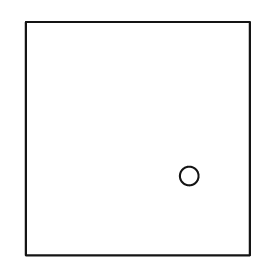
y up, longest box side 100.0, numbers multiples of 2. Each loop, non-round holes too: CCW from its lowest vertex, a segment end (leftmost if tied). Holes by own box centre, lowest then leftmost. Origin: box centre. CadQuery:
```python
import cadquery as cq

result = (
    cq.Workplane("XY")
    .moveTo(-48.0, -50.0)
    .lineTo(48.0, -50.0)
    .lineTo(48.0, 50.0)
    .lineTo(-48.0, 50.0)
    .close()
    .moveTo(22.0, -16.0)
    .circle(4.0)
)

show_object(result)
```